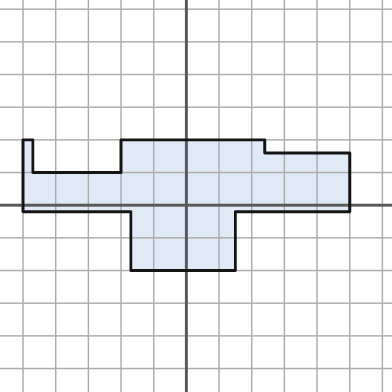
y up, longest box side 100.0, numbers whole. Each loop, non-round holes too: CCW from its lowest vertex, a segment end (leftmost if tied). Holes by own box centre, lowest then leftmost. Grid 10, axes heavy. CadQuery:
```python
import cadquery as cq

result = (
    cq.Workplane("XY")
    .moveTo(-17.0, -20.0)
    .lineTo(15.0, -20.0)
    .lineTo(15.0, -2.0)
    .lineTo(50.0, -2.0)
    .lineTo(50.0, 16.0)
    .lineTo(24.0, 16.0)
    .lineTo(24.0, 20.0)
    .lineTo(-20.0, 20.0)
    .lineTo(-20.0, 10.0)
    .lineTo(-47.0, 10.0)
    .lineTo(-47.0, 20.0)
    .lineTo(-50.0, 20.0)
    .lineTo(-50.0, -2.0)
    .lineTo(-17.0, -2.0)
    .close()
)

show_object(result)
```